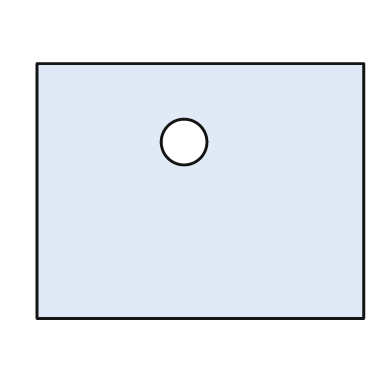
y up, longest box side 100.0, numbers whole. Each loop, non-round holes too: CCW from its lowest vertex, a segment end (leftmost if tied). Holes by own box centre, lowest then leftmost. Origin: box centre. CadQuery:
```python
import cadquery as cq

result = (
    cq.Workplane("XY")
    .moveTo(-50.0, -39.0)
    .lineTo(50.0, -39.0)
    .lineTo(50.0, 39.0)
    .lineTo(-50.0, 39.0)
    .close()
    .moveTo(-5.0, 15.0)
    .circle(7.0)
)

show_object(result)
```